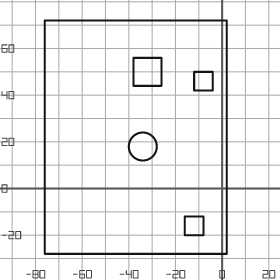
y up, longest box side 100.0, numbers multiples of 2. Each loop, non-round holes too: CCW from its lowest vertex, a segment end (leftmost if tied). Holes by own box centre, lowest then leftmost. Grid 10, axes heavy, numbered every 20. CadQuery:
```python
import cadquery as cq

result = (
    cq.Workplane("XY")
    .moveTo(-76.0, -28.0)
    .lineTo(2.0, -28.0)
    .lineTo(2.0, 72.0)
    .lineTo(-76.0, 72.0)
    .close()
    .moveTo(-16.0, -20.0)
    .lineTo(-8.0, -20.0)
    .lineTo(-8.0, -12.0)
    .lineTo(-16.0, -12.0)
    .close()
    .moveTo(-34.0, 18.0)
    .circle(6.0)
    .moveTo(-12.0, 42.0)
    .lineTo(-4.0, 42.0)
    .lineTo(-4.0, 50.0)
    .lineTo(-12.0, 50.0)
    .close()
    .moveTo(-38.0, 44.0)
    .lineTo(-26.0, 44.0)
    .lineTo(-26.0, 56.0)
    .lineTo(-38.0, 56.0)
    .close()
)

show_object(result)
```